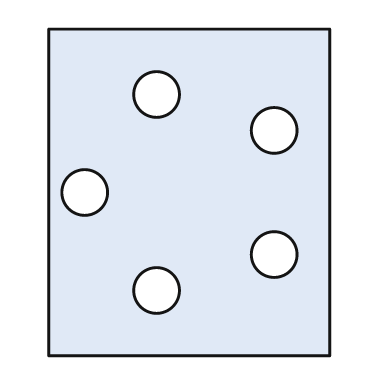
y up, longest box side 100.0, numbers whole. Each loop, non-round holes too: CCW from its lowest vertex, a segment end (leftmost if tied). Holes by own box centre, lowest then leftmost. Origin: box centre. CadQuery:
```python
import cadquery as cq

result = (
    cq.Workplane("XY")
    .moveTo(-43.0, -50.0)
    .lineTo(43.0, -50.0)
    .lineTo(43.0, 50.0)
    .lineTo(-43.0, 50.0)
    .close()
    .moveTo(-10.0, -30.0)
    .circle(7.0)
    .moveTo(26.0, -19.0)
    .circle(7.0)
    .moveTo(-32.0, 0.0)
    .circle(7.0)
    .moveTo(26.0, 19.0)
    .circle(7.0)
    .moveTo(-10.0, 30.0)
    .circle(7.0)
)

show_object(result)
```